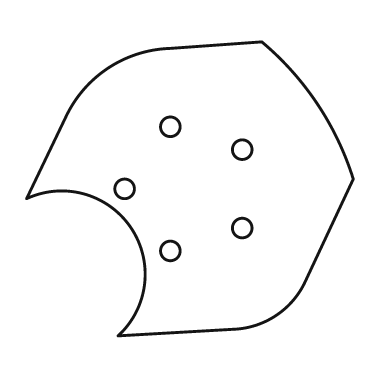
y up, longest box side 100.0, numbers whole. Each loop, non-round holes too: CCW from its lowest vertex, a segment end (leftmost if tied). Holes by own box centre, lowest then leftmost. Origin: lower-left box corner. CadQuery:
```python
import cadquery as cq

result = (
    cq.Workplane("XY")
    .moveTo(28.0, 0.0)
    .lineTo(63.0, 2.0)
    .threePointArc((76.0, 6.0), (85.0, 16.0))
    .lineTo(100.0, 48.0)
    .threePointArc((89.0, 71.0), (72.0, 90.0))
    .lineTo(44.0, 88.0)
    .threePointArc((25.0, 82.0), (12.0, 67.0))
    .lineTo(0.0, 42.0)
    .threePointArc((32.0, 33.0), (28.0, 0.0))
    .close()
    .moveTo(44.0, 26.0)
    .circle(3.0)
    .moveTo(66.0, 33.0)
    .circle(3.0)
    .moveTo(30.0, 45.0)
    .circle(3.0)
    .moveTo(66.0, 57.0)
    .circle(3.0)
    .moveTo(44.0, 64.0)
    .circle(3.0)
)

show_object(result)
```